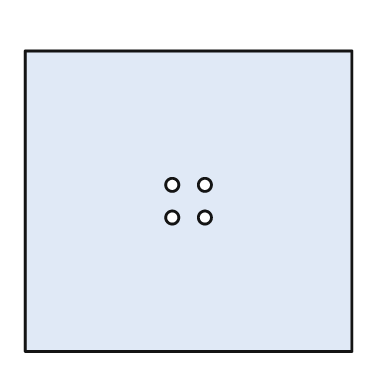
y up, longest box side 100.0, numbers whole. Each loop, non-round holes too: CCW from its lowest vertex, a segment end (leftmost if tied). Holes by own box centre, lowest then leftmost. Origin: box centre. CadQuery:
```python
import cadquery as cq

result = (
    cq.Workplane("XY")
    .moveTo(-50.0, -46.0)
    .lineTo(50.0, -46.0)
    .lineTo(50.0, 46.0)
    .lineTo(-50.0, 46.0)
    .close()
    .moveTo(-5.0, -5.0)
    .circle(2.0)
    .moveTo(5.0, -5.0)
    .circle(2.0)
    .moveTo(-5.0, 5.0)
    .circle(2.0)
    .moveTo(5.0, 5.0)
    .circle(2.0)
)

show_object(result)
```